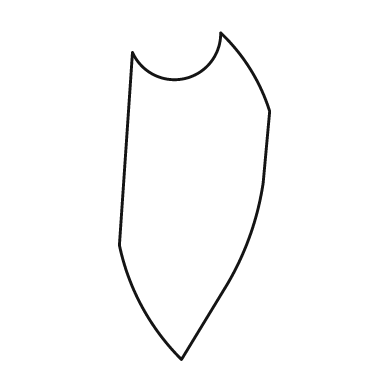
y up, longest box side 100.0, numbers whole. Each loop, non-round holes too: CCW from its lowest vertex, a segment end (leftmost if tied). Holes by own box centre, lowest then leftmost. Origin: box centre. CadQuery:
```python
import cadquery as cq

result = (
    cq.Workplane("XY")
    .moveTo(-4.0, -50.0)
    .lineTo(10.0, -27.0)
    .threePointArc((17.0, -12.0), (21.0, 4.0))
    .lineTo(23.0, 26.0)
    .threePointArc((17.0, 39.0), (8.0, 50.0))
    .threePointArc((-3.0, 36.0), (-19.0, 44.0))
    .lineTo(-23.0, -15.0)
    .threePointArc((-16.0, -34.0), (-4.0, -50.0))
    .close()
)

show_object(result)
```